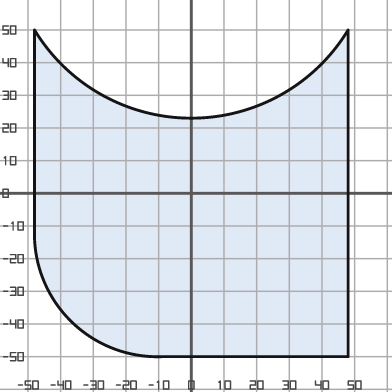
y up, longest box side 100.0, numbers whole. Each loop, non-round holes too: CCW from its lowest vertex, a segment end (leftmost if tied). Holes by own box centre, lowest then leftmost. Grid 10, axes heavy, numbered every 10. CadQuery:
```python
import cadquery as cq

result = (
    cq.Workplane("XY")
    .moveTo(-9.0, -50.0)
    .lineTo(48.0, -50.0)
    .lineTo(48.0, 50.0)
    .threePointArc((0.0, 23.0), (-48.0, 50.0))
    .lineTo(-48.0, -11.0)
    .threePointArc((-37.0, -39.0), (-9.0, -50.0))
    .close()
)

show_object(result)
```